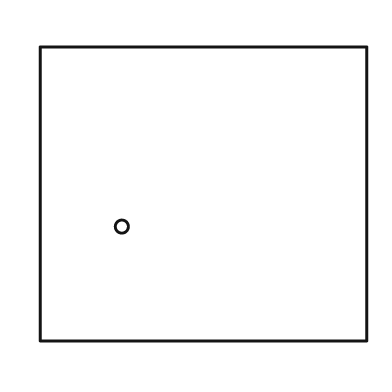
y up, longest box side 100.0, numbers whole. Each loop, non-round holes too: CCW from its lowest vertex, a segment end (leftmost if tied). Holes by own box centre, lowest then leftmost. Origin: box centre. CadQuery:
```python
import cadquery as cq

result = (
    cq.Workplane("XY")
    .moveTo(-50.0, -45.0)
    .lineTo(50.0, -45.0)
    .lineTo(50.0, 45.0)
    .lineTo(-50.0, 45.0)
    .close()
    .moveTo(-25.0, -10.0)
    .circle(2.0)
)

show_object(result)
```